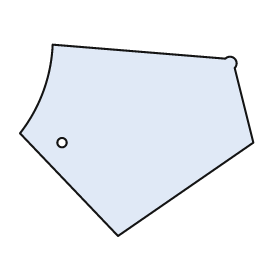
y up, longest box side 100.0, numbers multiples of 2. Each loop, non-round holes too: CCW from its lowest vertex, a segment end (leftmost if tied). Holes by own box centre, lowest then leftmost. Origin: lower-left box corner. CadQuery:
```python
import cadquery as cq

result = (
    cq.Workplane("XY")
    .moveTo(42.0, 0.0)
    .lineTo(100.0, 40.0)
    .lineTo(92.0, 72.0)
    .threePointArc((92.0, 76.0), (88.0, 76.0))
    .lineTo(14.0, 82.0)
    .threePointArc((10.0, 62.0), (0.0, 44.0))
    .close()
    .moveTo(18.0, 40.0)
    .circle(2.0)
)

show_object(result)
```